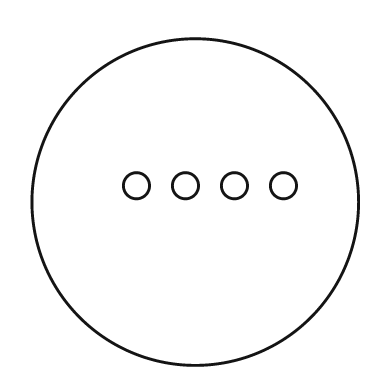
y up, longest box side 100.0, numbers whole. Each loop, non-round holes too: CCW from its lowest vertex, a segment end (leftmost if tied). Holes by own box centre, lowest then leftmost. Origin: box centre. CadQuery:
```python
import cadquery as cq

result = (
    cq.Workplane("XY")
    .moveTo(0.0, 0.0)
    .circle(50.0)
    .moveTo(-18.0, 5.0)
    .circle(4.0)
    .moveTo(-3.0, 5.0)
    .circle(4.0)
    .moveTo(12.0, 5.0)
    .circle(4.0)
    .moveTo(27.0, 5.0)
    .circle(4.0)
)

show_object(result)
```